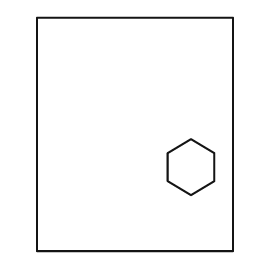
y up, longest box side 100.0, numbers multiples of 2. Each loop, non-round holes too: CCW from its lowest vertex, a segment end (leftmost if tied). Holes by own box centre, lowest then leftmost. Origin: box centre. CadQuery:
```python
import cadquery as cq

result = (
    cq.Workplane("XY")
    .moveTo(-42.0, -50.0)
    .lineTo(42.0, -50.0)
    .lineTo(42.0, 50.0)
    .lineTo(-42.0, 50.0)
    .close()
    .moveTo(24.0, -26.0)
    .lineTo(34.0, -20.0)
    .lineTo(34.0, -8.0)
    .lineTo(24.0, -2.0)
    .lineTo(14.0, -8.0)
    .lineTo(14.0, -20.0)
    .close()
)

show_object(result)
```